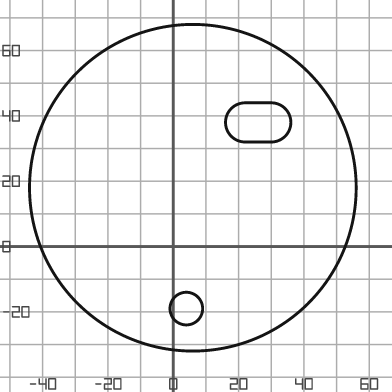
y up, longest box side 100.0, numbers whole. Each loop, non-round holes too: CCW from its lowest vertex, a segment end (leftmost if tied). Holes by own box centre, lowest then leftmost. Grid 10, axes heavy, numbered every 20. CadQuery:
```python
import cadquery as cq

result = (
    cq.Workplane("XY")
    .moveTo(6.0, 18.0)
    .circle(50.0)
    .moveTo(4.0, -19.0)
    .circle(5.0)
    .moveTo(22.0, 32.0)
    .lineTo(30.0, 32.0)
    .threePointArc((36.0, 38.0), (30.0, 44.0))
    .lineTo(22.0, 44.0)
    .threePointArc((16.0, 38.0), (22.0, 32.0))
    .close()
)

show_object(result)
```